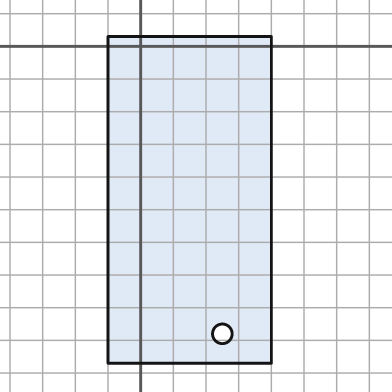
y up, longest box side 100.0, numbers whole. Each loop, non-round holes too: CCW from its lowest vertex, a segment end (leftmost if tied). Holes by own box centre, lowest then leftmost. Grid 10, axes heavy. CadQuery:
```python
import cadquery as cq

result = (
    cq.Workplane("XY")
    .moveTo(-10.0, -97.0)
    .lineTo(40.0, -97.0)
    .lineTo(40.0, 3.0)
    .lineTo(-10.0, 3.0)
    .close()
    .moveTo(25.0, -88.0)
    .circle(3.0)
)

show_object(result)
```